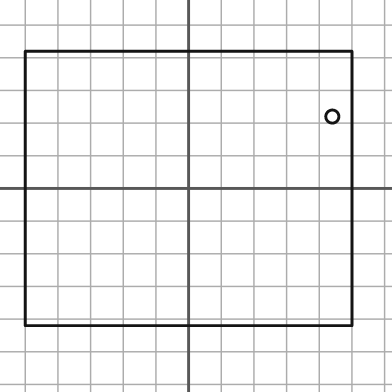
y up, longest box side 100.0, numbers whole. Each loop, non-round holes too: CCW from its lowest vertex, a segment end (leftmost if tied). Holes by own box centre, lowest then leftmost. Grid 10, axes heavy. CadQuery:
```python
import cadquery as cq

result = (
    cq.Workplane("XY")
    .moveTo(-50.0, -42.0)
    .lineTo(50.0, -42.0)
    .lineTo(50.0, 42.0)
    .lineTo(-50.0, 42.0)
    .close()
    .moveTo(44.0, 22.0)
    .circle(2.0)
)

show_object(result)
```